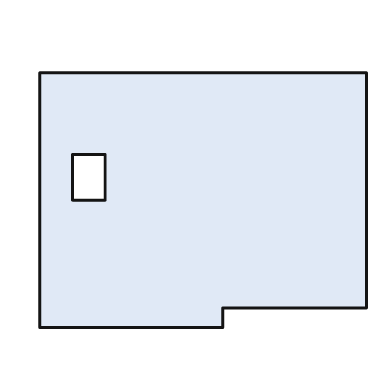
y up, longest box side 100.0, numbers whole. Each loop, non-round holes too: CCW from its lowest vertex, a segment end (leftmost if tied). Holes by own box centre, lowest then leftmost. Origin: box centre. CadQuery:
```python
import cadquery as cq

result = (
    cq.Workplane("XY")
    .moveTo(-50.0, -39.0)
    .lineTo(6.0, -39.0)
    .lineTo(6.0, -33.0)
    .lineTo(50.0, -33.0)
    .lineTo(50.0, 39.0)
    .lineTo(-50.0, 39.0)
    .close()
    .moveTo(-40.0, 0.0)
    .lineTo(-30.0, 0.0)
    .lineTo(-30.0, 14.0)
    .lineTo(-40.0, 14.0)
    .close()
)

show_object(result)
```